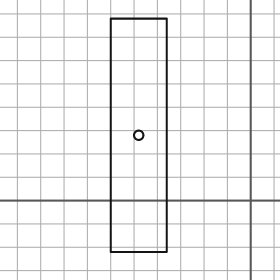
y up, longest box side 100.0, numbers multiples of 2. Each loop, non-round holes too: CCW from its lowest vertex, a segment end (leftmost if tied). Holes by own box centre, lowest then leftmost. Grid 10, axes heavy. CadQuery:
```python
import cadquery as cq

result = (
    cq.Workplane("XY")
    .moveTo(-60.0, -22.0)
    .lineTo(-36.0, -22.0)
    .lineTo(-36.0, 78.0)
    .lineTo(-60.0, 78.0)
    .close()
    .moveTo(-48.0, 28.0)
    .circle(2.0)
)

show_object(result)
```